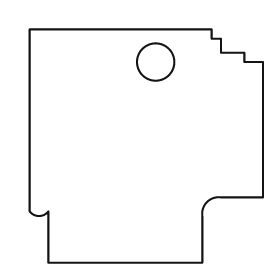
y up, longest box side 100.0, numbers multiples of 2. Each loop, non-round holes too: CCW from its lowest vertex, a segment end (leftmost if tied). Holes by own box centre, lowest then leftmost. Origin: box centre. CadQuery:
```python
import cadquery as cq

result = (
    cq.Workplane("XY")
    .moveTo(-42.0, -50.0)
    .lineTo(24.0, -50.0)
    .lineTo(24.0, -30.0)
    .threePointArc((26.0, -24.0), (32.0, -22.0))
    .lineTo(50.0, -22.0)
    .lineTo(50.0, 36.0)
    .lineTo(42.0, 36.0)
    .lineTo(42.0, 40.0)
    .lineTo(32.0, 40.0)
    .lineTo(32.0, 46.0)
    .lineTo(28.0, 46.0)
    .lineTo(28.0, 50.0)
    .lineTo(-50.0, 50.0)
    .lineTo(-50.0, -28.0)
    .threePointArc((-46.0, -30.0), (-42.0, -28.0))
    .close()
    .moveTo(4.0, 36.0)
    .circle(8.0)
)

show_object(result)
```